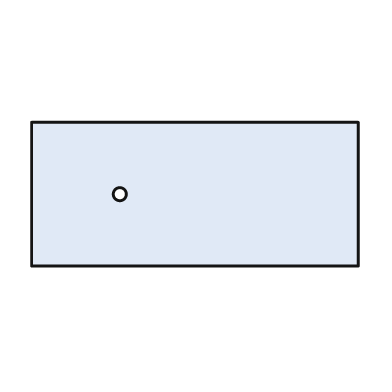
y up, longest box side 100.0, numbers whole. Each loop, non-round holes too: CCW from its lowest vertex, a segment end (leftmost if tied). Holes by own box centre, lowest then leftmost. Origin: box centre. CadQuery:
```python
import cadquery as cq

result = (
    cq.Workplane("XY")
    .moveTo(-50.0, -22.0)
    .lineTo(50.0, -22.0)
    .lineTo(50.0, 22.0)
    .lineTo(-50.0, 22.0)
    .close()
    .moveTo(-23.0, 0.0)
    .circle(2.0)
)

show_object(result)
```